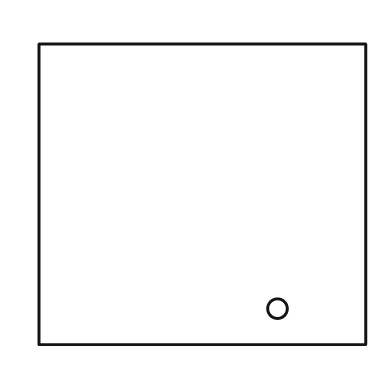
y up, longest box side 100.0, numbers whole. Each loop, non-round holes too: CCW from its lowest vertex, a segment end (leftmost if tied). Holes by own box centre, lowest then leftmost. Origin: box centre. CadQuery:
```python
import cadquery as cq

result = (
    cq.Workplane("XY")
    .moveTo(-50.0, -46.0)
    .lineTo(50.0, -46.0)
    .lineTo(50.0, 46.0)
    .lineTo(-50.0, 46.0)
    .close()
    .moveTo(23.0, -35.0)
    .circle(3.0)
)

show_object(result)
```